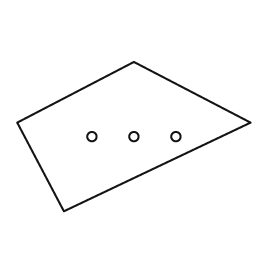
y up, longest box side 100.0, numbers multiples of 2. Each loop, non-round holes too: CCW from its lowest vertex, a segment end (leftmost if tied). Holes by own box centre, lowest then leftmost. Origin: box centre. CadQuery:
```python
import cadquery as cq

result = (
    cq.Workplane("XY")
    .moveTo(-30.0, -32.0)
    .lineTo(50.0, 6.0)
    .lineTo(0.0, 32.0)
    .lineTo(-50.0, 6.0)
    .close()
    .moveTo(-18.0, 0.0)
    .circle(2.0)
    .moveTo(0.0, 0.0)
    .circle(2.0)
    .moveTo(18.0, 0.0)
    .circle(2.0)
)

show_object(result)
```